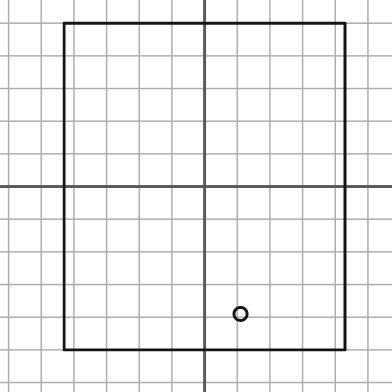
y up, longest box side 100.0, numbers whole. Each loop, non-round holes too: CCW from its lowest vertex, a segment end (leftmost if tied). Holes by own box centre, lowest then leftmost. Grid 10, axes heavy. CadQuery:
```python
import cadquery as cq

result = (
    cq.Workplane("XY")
    .moveTo(-43.0, -50.0)
    .lineTo(43.0, -50.0)
    .lineTo(43.0, 50.0)
    .lineTo(-43.0, 50.0)
    .close()
    .moveTo(11.0, -39.0)
    .circle(2.0)
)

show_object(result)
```